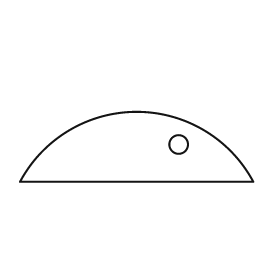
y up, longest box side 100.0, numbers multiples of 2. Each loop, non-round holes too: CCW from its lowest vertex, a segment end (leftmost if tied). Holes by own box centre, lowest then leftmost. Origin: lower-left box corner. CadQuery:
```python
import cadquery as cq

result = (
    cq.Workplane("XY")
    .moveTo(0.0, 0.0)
    .lineTo(100.0, 0.0)
    .threePointArc((50.0, 30.0), (0.0, 0.0))
    .close()
    .moveTo(68.0, 16.0)
    .circle(4.0)
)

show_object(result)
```